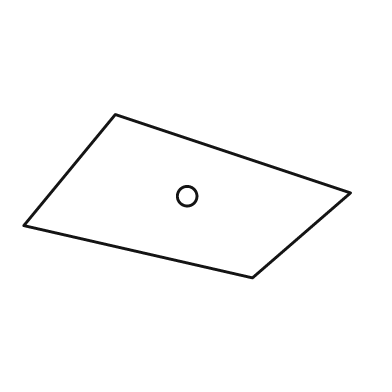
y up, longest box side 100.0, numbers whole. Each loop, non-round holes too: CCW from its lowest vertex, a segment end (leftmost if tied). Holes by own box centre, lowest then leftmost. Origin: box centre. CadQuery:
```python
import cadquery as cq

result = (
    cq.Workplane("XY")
    .moveTo(20.0, -25.0)
    .lineTo(50.0, 1.0)
    .lineTo(-22.0, 25.0)
    .lineTo(-50.0, -9.0)
    .close()
    .moveTo(0.0, 0.0)
    .circle(3.0)
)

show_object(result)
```